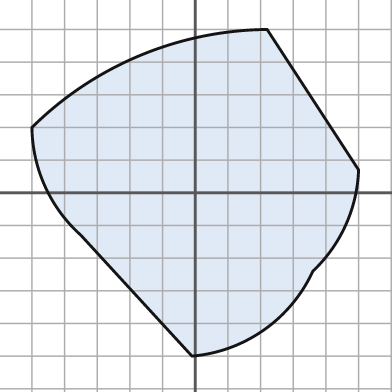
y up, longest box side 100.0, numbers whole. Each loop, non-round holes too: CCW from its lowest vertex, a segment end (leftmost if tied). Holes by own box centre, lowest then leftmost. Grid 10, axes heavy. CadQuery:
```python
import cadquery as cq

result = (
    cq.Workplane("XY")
    .moveTo(-1.0, -50.0)
    .threePointArc((21.0, -42.0), (36.0, -24.0))
    .threePointArc((46.0, -10.0), (50.0, 7.0))
    .lineTo(22.0, 50.0)
    .threePointArc((-17.0, 42.0), (-50.0, 20.0))
    .threePointArc((-46.0, 2.0), (-35.0, -13.0))
    .close()
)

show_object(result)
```